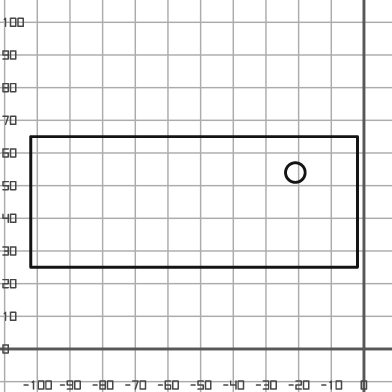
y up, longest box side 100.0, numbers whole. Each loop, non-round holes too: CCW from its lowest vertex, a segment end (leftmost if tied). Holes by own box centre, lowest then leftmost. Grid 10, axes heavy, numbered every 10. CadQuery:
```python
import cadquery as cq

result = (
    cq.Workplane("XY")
    .moveTo(-102.0, 25.0)
    .lineTo(-2.0, 25.0)
    .lineTo(-2.0, 65.0)
    .lineTo(-102.0, 65.0)
    .close()
    .moveTo(-21.0, 54.0)
    .circle(3.0)
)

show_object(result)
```